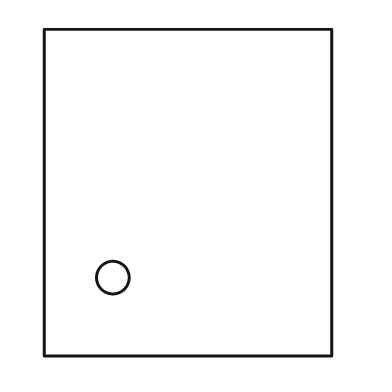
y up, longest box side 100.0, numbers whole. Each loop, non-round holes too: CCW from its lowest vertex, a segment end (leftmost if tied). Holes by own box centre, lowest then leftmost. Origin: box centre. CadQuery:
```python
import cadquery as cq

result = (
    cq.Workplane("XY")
    .moveTo(-44.0, -50.0)
    .lineTo(44.0, -50.0)
    .lineTo(44.0, 50.0)
    .lineTo(-44.0, 50.0)
    .close()
    .moveTo(-23.0, -26.0)
    .circle(5.0)
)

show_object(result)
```